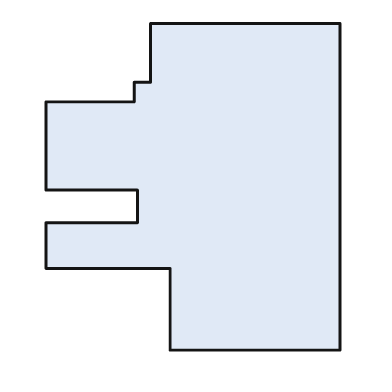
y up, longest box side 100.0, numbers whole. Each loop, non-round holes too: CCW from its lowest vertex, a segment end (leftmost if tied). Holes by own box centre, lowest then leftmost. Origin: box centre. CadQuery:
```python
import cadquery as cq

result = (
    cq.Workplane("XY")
    .moveTo(-7.0, -50.0)
    .lineTo(45.0, -50.0)
    .lineTo(45.0, 50.0)
    .lineTo(-13.0, 50.0)
    .lineTo(-13.0, 32.0)
    .lineTo(-18.0, 32.0)
    .lineTo(-18.0, 26.0)
    .lineTo(-45.0, 26.0)
    .lineTo(-45.0, -1.0)
    .lineTo(-17.0, -1.0)
    .lineTo(-17.0, -11.0)
    .lineTo(-45.0, -11.0)
    .lineTo(-45.0, -25.0)
    .lineTo(-7.0, -25.0)
    .close()
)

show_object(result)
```